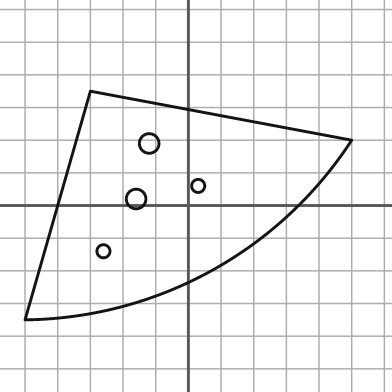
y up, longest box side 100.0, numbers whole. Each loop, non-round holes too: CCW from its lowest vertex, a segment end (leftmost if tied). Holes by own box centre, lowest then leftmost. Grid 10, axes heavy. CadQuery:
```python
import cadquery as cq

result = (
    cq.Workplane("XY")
    .moveTo(-50.0, -35.0)
    .threePointArc((7.0, -20.0), (50.0, 20.0))
    .lineTo(-30.0, 35.0)
    .close()
    .moveTo(-26.0, -14.0)
    .circle(2.0)
    .moveTo(-16.0, 2.0)
    .circle(3.0)
    .moveTo(3.0, 6.0)
    .circle(2.0)
    .moveTo(-12.0, 19.0)
    .circle(3.0)
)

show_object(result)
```